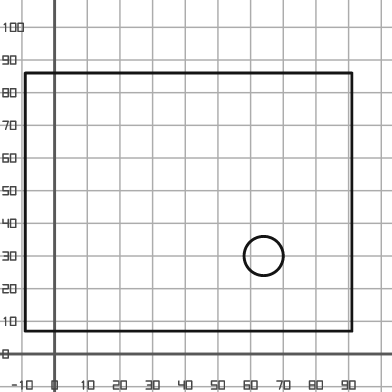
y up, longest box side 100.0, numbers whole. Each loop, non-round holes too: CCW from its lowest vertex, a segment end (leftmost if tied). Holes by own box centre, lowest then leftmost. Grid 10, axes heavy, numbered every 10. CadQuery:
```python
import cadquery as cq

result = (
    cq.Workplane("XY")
    .moveTo(-9.0, 7.0)
    .lineTo(91.0, 7.0)
    .lineTo(91.0, 86.0)
    .lineTo(-9.0, 86.0)
    .close()
    .moveTo(64.0, 30.0)
    .circle(6.0)
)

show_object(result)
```